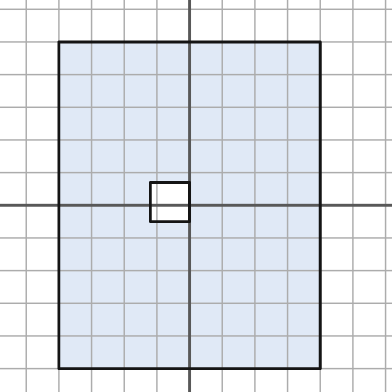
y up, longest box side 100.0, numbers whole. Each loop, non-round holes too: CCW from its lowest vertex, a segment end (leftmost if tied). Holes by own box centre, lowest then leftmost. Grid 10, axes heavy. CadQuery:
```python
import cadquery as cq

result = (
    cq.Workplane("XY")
    .moveTo(-40.0, -50.0)
    .lineTo(40.0, -50.0)
    .lineTo(40.0, 50.0)
    .lineTo(-40.0, 50.0)
    .close()
    .moveTo(-12.0, -5.0)
    .lineTo(0.0, -5.0)
    .lineTo(0.0, 7.0)
    .lineTo(-12.0, 7.0)
    .close()
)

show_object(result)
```